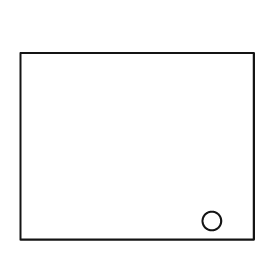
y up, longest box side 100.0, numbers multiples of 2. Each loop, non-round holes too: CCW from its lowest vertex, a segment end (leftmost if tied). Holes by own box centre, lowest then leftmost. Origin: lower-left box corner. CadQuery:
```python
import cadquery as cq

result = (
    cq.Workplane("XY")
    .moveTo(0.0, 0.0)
    .lineTo(100.0, 0.0)
    .lineTo(100.0, 80.0)
    .lineTo(0.0, 80.0)
    .close()
    .moveTo(82.0, 8.0)
    .circle(4.0)
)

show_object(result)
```